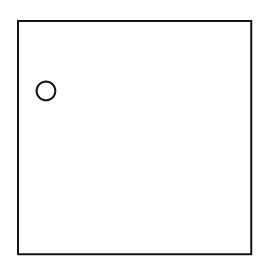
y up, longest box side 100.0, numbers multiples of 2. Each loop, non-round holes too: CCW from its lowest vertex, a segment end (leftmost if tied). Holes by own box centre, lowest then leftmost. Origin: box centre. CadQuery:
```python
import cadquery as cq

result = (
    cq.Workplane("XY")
    .moveTo(-50.0, -50.0)
    .lineTo(50.0, -50.0)
    .lineTo(50.0, 50.0)
    .lineTo(-50.0, 50.0)
    .close()
    .moveTo(-38.0, 20.0)
    .circle(4.0)
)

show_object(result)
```